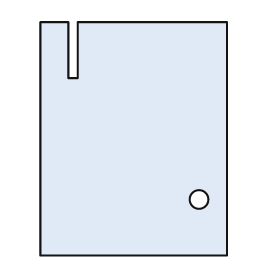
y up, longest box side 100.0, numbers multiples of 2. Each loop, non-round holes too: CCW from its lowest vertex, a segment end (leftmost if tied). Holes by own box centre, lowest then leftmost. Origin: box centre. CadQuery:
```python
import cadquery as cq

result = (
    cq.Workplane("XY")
    .moveTo(-40.0, -50.0)
    .lineTo(40.0, -50.0)
    .lineTo(40.0, 50.0)
    .lineTo(-24.0, 50.0)
    .lineTo(-24.0, 26.0)
    .lineTo(-28.0, 26.0)
    .lineTo(-28.0, 50.0)
    .lineTo(-40.0, 50.0)
    .close()
    .moveTo(28.0, -26.0)
    .circle(4.0)
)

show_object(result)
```